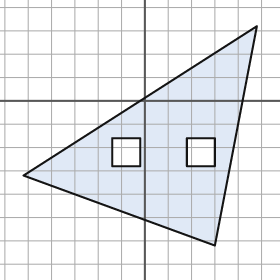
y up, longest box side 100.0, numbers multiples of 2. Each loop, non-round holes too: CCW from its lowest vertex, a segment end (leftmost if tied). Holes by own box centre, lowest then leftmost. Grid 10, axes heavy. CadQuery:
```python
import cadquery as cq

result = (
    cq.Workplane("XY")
    .moveTo(30.0, -62.0)
    .lineTo(48.0, 32.0)
    .lineTo(-52.0, -32.0)
    .close()
    .moveTo(-14.0, -28.0)
    .lineTo(-2.0, -28.0)
    .lineTo(-2.0, -16.0)
    .lineTo(-14.0, -16.0)
    .close()
    .moveTo(18.0, -28.0)
    .lineTo(30.0, -28.0)
    .lineTo(30.0, -16.0)
    .lineTo(18.0, -16.0)
    .close()
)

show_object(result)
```